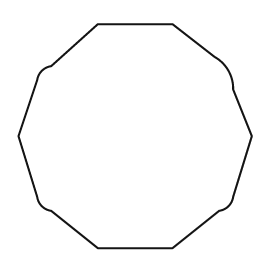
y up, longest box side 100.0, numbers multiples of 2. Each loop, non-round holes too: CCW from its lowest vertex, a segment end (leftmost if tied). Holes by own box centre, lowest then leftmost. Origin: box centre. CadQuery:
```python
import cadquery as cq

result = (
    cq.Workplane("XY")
    .moveTo(-16.0, -48.0)
    .lineTo(16.0, -48.0)
    .lineTo(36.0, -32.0)
    .threePointArc((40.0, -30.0), (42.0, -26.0))
    .lineTo(50.0, 0.0)
    .lineTo(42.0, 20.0)
    .threePointArc((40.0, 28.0), (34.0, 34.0))
    .lineTo(16.0, 48.0)
    .lineTo(-16.0, 48.0)
    .lineTo(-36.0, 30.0)
    .threePointArc((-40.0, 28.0), (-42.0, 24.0))
    .lineTo(-50.0, 0.0)
    .lineTo(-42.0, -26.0)
    .threePointArc((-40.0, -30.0), (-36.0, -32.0))
    .close()
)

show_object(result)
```